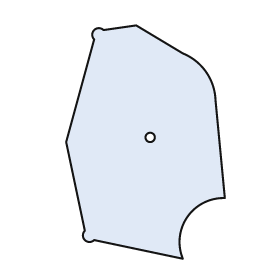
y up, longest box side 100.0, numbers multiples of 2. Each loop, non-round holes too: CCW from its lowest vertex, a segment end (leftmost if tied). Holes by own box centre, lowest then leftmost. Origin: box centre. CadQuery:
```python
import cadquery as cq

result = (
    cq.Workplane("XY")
    .moveTo(16.0, -50.0)
    .threePointArc((18.0, -32.0), (34.0, -24.0))
    .lineTo(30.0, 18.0)
    .threePointArc((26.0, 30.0), (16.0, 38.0))
    .lineTo(-4.0, 50.0)
    .lineTo(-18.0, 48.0)
    .threePointArc((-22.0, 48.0), (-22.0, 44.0))
    .lineTo(-34.0, 0.0)
    .lineTo(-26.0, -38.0)
    .threePointArc((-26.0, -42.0), (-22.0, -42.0))
    .close()
    .moveTo(2.0, 2.0)
    .circle(2.0)
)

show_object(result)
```